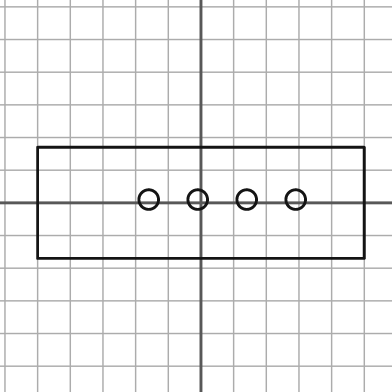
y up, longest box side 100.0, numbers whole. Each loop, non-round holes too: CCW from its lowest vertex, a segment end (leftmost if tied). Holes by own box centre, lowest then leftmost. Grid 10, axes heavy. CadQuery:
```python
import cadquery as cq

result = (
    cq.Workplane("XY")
    .moveTo(-50.0, -17.0)
    .lineTo(50.0, -17.0)
    .lineTo(50.0, 17.0)
    .lineTo(-50.0, 17.0)
    .close()
    .moveTo(-16.0, 1.0)
    .circle(3.0)
    .moveTo(-1.0, 1.0)
    .circle(3.0)
    .moveTo(14.0, 1.0)
    .circle(3.0)
    .moveTo(29.0, 1.0)
    .circle(3.0)
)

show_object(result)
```